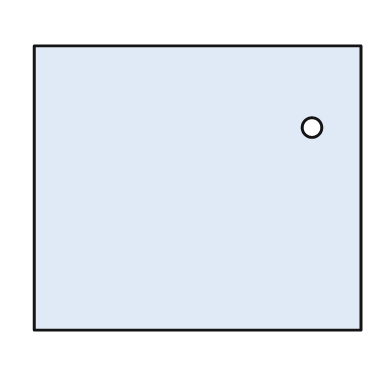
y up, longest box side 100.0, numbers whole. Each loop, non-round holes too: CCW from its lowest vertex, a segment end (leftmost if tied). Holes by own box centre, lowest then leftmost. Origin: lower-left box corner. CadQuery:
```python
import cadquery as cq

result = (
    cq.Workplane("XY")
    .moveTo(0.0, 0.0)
    .lineTo(100.0, 0.0)
    .lineTo(100.0, 87.0)
    .lineTo(0.0, 87.0)
    .close()
    .moveTo(85.0, 62.0)
    .circle(3.0)
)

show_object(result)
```